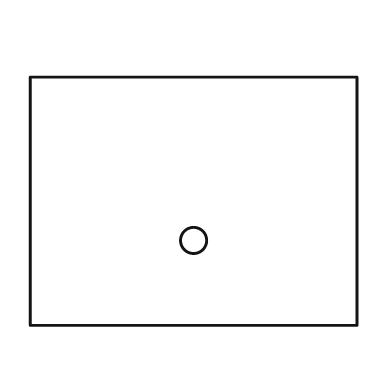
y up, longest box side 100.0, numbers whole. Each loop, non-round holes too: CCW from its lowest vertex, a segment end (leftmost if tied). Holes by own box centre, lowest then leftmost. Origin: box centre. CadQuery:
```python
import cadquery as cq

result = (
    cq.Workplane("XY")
    .moveTo(-50.0, -38.0)
    .lineTo(50.0, -38.0)
    .lineTo(50.0, 38.0)
    .lineTo(-50.0, 38.0)
    .close()
    .moveTo(0.0, -12.0)
    .circle(4.0)
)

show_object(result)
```